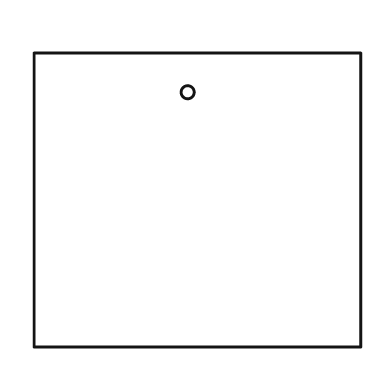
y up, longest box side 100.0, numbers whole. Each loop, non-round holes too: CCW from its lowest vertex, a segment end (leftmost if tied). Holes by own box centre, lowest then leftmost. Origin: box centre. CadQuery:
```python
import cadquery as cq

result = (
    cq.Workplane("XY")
    .moveTo(-50.0, -45.0)
    .lineTo(50.0, -45.0)
    .lineTo(50.0, 45.0)
    .lineTo(-50.0, 45.0)
    .close()
    .moveTo(-3.0, 33.0)
    .circle(2.0)
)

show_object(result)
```